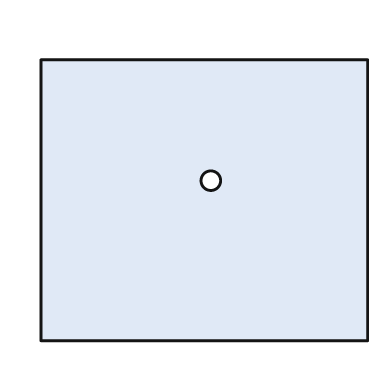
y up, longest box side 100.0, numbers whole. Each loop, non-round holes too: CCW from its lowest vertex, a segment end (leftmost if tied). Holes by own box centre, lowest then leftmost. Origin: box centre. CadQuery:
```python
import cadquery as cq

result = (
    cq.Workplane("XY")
    .moveTo(-50.0, -43.0)
    .lineTo(50.0, -43.0)
    .lineTo(50.0, 43.0)
    .lineTo(-50.0, 43.0)
    .close()
    .moveTo(2.0, 6.0)
    .circle(3.0)
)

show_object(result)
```